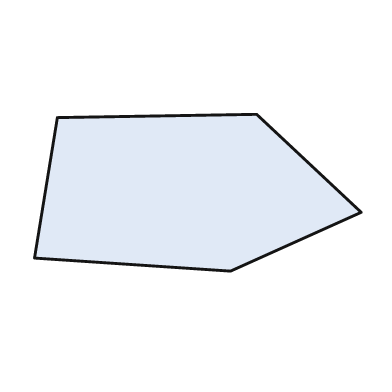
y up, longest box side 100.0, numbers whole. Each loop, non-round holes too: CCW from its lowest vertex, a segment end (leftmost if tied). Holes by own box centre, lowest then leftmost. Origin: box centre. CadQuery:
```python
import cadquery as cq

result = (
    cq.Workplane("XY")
    .moveTo(10.0, -24.0)
    .lineTo(50.0, -6.0)
    .lineTo(18.0, 24.0)
    .lineTo(-43.0, 23.0)
    .lineTo(-50.0, -20.0)
    .close()
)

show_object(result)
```